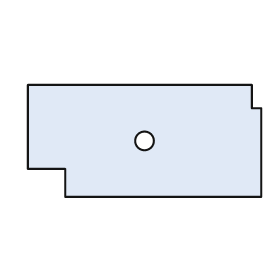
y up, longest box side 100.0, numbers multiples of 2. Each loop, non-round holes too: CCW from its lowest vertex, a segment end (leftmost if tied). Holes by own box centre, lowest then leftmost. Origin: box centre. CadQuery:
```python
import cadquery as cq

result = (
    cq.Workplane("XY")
    .moveTo(-34.0, -24.0)
    .lineTo(50.0, -24.0)
    .lineTo(50.0, 14.0)
    .lineTo(46.0, 14.0)
    .lineTo(46.0, 24.0)
    .lineTo(-50.0, 24.0)
    .lineTo(-50.0, -12.0)
    .lineTo(-34.0, -12.0)
    .close()
    .moveTo(0.0, 0.0)
    .circle(4.0)
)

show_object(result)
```